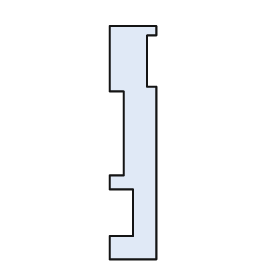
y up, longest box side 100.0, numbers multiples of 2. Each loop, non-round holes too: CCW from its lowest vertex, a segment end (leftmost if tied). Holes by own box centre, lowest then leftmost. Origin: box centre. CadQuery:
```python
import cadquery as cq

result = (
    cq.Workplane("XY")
    .moveTo(-10.0, -50.0)
    .lineTo(10.0, -50.0)
    .lineTo(10.0, 24.0)
    .lineTo(6.0, 24.0)
    .lineTo(6.0, 46.0)
    .lineTo(10.0, 46.0)
    .lineTo(10.0, 50.0)
    .lineTo(-10.0, 50.0)
    .lineTo(-10.0, 22.0)
    .lineTo(-4.0, 22.0)
    .lineTo(-4.0, -14.0)
    .lineTo(-10.0, -14.0)
    .lineTo(-10.0, -20.0)
    .lineTo(0.0, -20.0)
    .lineTo(0.0, -40.0)
    .lineTo(-10.0, -40.0)
    .close()
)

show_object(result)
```